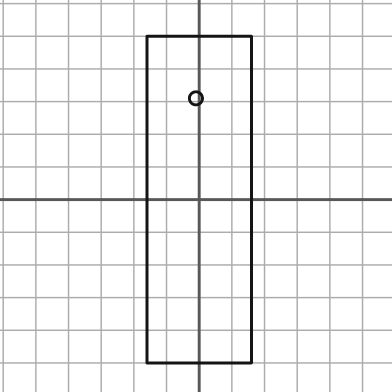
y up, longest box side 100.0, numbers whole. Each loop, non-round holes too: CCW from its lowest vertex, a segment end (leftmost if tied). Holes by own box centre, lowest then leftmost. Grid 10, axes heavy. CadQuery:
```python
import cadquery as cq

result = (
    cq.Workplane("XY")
    .moveTo(-16.0, -50.0)
    .lineTo(16.0, -50.0)
    .lineTo(16.0, 50.0)
    .lineTo(-16.0, 50.0)
    .close()
    .moveTo(-1.0, 31.0)
    .circle(2.0)
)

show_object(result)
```